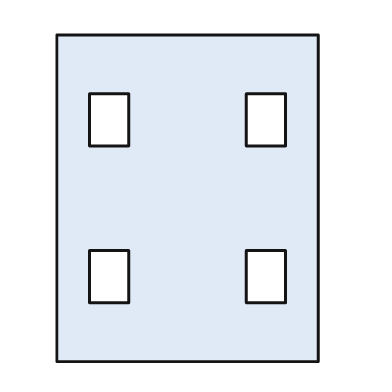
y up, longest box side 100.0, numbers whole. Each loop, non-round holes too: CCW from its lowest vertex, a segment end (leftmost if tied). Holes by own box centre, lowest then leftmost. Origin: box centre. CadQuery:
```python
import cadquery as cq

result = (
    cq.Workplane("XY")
    .moveTo(-40.0, -50.0)
    .lineTo(40.0, -50.0)
    .lineTo(40.0, 50.0)
    .lineTo(-40.0, 50.0)
    .close()
    .moveTo(-30.0, -32.0)
    .lineTo(-18.0, -32.0)
    .lineTo(-18.0, -16.0)
    .lineTo(-30.0, -16.0)
    .close()
    .moveTo(18.0, -32.0)
    .lineTo(30.0, -32.0)
    .lineTo(30.0, -16.0)
    .lineTo(18.0, -16.0)
    .close()
    .moveTo(-30.0, 16.0)
    .lineTo(-18.0, 16.0)
    .lineTo(-18.0, 32.0)
    .lineTo(-30.0, 32.0)
    .close()
    .moveTo(18.0, 16.0)
    .lineTo(30.0, 16.0)
    .lineTo(30.0, 32.0)
    .lineTo(18.0, 32.0)
    .close()
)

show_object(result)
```